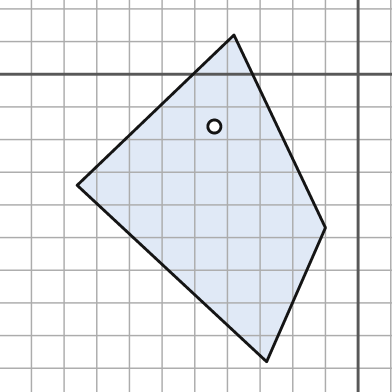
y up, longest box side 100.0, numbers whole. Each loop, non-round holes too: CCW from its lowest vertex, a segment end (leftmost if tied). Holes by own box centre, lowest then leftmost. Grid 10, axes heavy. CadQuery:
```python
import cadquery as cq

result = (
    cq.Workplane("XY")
    .moveTo(-28.0, -88.0)
    .lineTo(-10.0, -47.0)
    .lineTo(-38.0, 12.0)
    .lineTo(-86.0, -34.0)
    .close()
    .moveTo(-44.0, -16.0)
    .circle(2.0)
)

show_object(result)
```